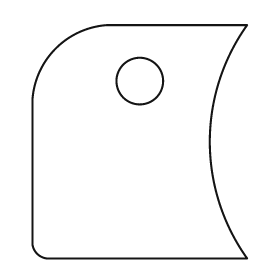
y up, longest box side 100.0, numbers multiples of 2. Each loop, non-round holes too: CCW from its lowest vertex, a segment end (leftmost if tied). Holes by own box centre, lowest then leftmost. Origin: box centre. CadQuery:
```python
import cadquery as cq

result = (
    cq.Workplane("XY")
    .moveTo(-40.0, -50.0)
    .lineTo(46.0, -50.0)
    .threePointArc((30.0, 0.0), (46.0, 50.0))
    .lineTo(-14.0, 50.0)
    .threePointArc((-36.0, 40.0), (-46.0, 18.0))
    .lineTo(-46.0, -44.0)
    .threePointArc((-44.0, -48.0), (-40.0, -50.0))
    .close()
    .moveTo(0.0, 26.0)
    .circle(10.0)
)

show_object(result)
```